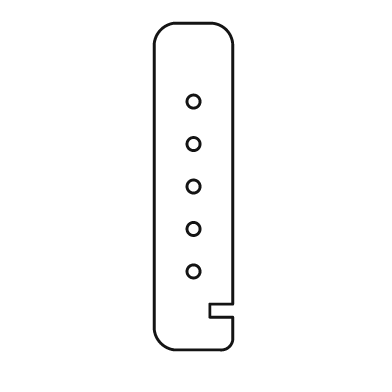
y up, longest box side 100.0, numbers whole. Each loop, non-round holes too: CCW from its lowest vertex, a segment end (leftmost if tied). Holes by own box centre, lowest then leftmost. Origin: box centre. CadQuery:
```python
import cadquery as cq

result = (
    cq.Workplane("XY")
    .moveTo(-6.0, -50.0)
    .lineTo(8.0, -50.0)
    .threePointArc((11.0, -49.0), (12.0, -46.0))
    .lineTo(12.0, -40.0)
    .lineTo(5.0, -40.0)
    .lineTo(5.0, -36.0)
    .lineTo(12.0, -36.0)
    .lineTo(12.0, 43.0)
    .threePointArc((10.0, 48.0), (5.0, 50.0))
    .lineTo(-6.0, 50.0)
    .threePointArc((-10.0, 48.0), (-12.0, 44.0))
    .lineTo(-12.0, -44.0)
    .threePointArc((-10.0, -48.0), (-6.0, -50.0))
    .close()
    .moveTo(0.0, -26.0)
    .circle(2.0)
    .moveTo(0.0, -13.0)
    .circle(2.0)
    .moveTo(0.0, 0.0)
    .circle(2.0)
    .moveTo(0.0, 13.0)
    .circle(2.0)
    .moveTo(0.0, 26.0)
    .circle(2.0)
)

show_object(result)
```